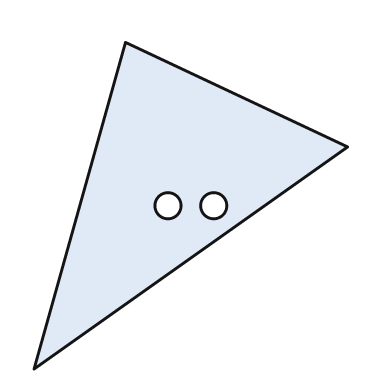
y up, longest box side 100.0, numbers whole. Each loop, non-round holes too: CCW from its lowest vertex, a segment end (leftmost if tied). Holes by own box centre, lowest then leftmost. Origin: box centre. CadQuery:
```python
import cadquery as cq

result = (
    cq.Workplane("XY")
    .moveTo(-48.0, -50.0)
    .lineTo(48.0, 18.0)
    .lineTo(-20.0, 50.0)
    .close()
    .moveTo(-7.0, 0.0)
    .circle(4.0)
    .moveTo(7.0, 0.0)
    .circle(4.0)
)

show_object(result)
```